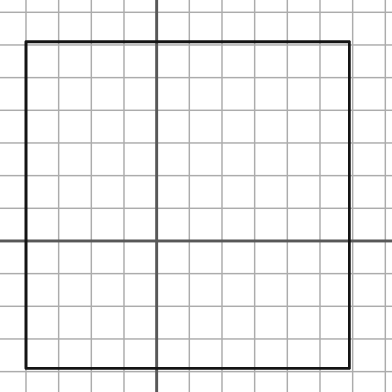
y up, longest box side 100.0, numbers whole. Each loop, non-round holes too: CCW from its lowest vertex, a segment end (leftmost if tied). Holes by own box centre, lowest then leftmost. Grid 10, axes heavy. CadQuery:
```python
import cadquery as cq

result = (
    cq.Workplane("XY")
    .moveTo(-40.0, -39.0)
    .lineTo(59.0, -39.0)
    .lineTo(59.0, 61.0)
    .lineTo(-40.0, 61.0)
    .close()
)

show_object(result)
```